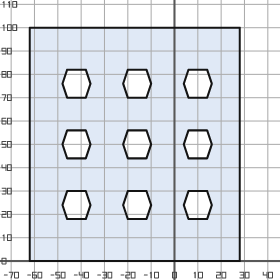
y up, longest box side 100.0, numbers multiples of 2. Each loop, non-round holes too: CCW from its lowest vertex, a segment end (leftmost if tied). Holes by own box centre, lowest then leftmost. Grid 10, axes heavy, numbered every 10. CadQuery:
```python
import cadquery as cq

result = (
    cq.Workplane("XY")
    .moveTo(-62.0, 0.0)
    .lineTo(28.0, 0.0)
    .lineTo(28.0, 100.0)
    .lineTo(-62.0, 100.0)
    .close()
    .moveTo(-46.0, 18.0)
    .lineTo(-38.0, 18.0)
    .lineTo(-36.0, 24.0)
    .lineTo(-38.0, 30.0)
    .lineTo(-46.0, 30.0)
    .lineTo(-48.0, 24.0)
    .close()
    .moveTo(-20.0, 18.0)
    .lineTo(-12.0, 18.0)
    .lineTo(-10.0, 24.0)
    .lineTo(-12.0, 30.0)
    .lineTo(-20.0, 30.0)
    .lineTo(-22.0, 24.0)
    .close()
    .moveTo(6.0, 18.0)
    .lineTo(14.0, 18.0)
    .lineTo(16.0, 24.0)
    .lineTo(14.0, 30.0)
    .lineTo(6.0, 30.0)
    .lineTo(4.0, 24.0)
    .close()
    .moveTo(-46.0, 44.0)
    .lineTo(-38.0, 44.0)
    .lineTo(-36.0, 50.0)
    .lineTo(-38.0, 56.0)
    .lineTo(-46.0, 56.0)
    .lineTo(-48.0, 50.0)
    .close()
    .moveTo(-20.0, 44.0)
    .lineTo(-12.0, 44.0)
    .lineTo(-10.0, 50.0)
    .lineTo(-12.0, 56.0)
    .lineTo(-20.0, 56.0)
    .lineTo(-22.0, 50.0)
    .close()
    .moveTo(6.0, 44.0)
    .lineTo(14.0, 44.0)
    .lineTo(16.0, 50.0)
    .lineTo(14.0, 56.0)
    .lineTo(6.0, 56.0)
    .lineTo(4.0, 50.0)
    .close()
    .moveTo(-46.0, 70.0)
    .lineTo(-38.0, 70.0)
    .lineTo(-36.0, 76.0)
    .lineTo(-38.0, 82.0)
    .lineTo(-46.0, 82.0)
    .lineTo(-48.0, 76.0)
    .close()
    .moveTo(-20.0, 70.0)
    .lineTo(-12.0, 70.0)
    .lineTo(-10.0, 76.0)
    .lineTo(-12.0, 82.0)
    .lineTo(-20.0, 82.0)
    .lineTo(-22.0, 76.0)
    .close()
    .moveTo(6.0, 70.0)
    .lineTo(14.0, 70.0)
    .lineTo(16.0, 76.0)
    .lineTo(14.0, 82.0)
    .lineTo(6.0, 82.0)
    .lineTo(4.0, 76.0)
    .close()
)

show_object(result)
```